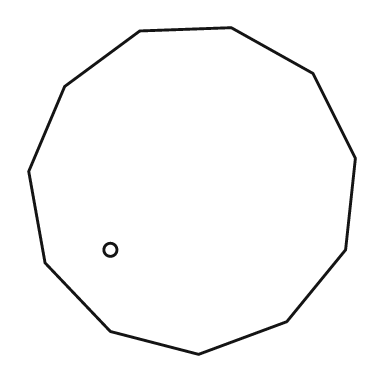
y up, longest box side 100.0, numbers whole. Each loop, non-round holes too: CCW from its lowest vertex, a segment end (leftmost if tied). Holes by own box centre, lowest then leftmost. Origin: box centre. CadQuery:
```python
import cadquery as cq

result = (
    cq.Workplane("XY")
    .moveTo(2.0, -50.0)
    .lineTo(29.0, -40.0)
    .lineTo(47.0, -18.0)
    .lineTo(50.0, 10.0)
    .lineTo(37.0, 36.0)
    .lineTo(12.0, 50.0)
    .lineTo(-16.0, 49.0)
    .lineTo(-39.0, 32.0)
    .lineTo(-50.0, 6.0)
    .lineTo(-45.0, -22.0)
    .lineTo(-25.0, -43.0)
    .close()
    .moveTo(-25.0, -18.0)
    .circle(2.0)
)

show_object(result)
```